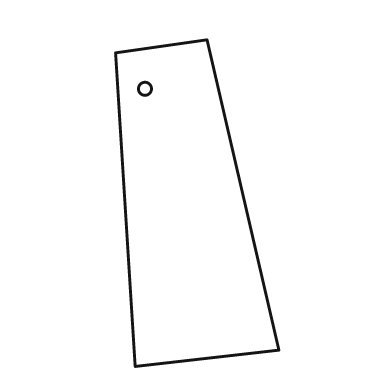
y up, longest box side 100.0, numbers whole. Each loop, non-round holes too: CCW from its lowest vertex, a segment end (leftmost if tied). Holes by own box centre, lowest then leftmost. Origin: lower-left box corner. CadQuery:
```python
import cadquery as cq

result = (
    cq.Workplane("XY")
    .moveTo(6.0, 0.0)
    .lineTo(50.0, 5.0)
    .lineTo(28.0, 100.0)
    .lineTo(0.0, 96.0)
    .close()
    .moveTo(9.0, 85.0)
    .circle(2.0)
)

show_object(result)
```